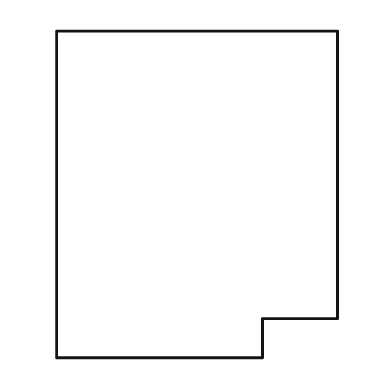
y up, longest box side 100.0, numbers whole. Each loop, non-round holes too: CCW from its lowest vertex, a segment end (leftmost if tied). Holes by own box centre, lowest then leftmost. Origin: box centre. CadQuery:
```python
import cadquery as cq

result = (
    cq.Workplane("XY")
    .moveTo(-43.0, -50.0)
    .lineTo(20.0, -50.0)
    .lineTo(20.0, -38.0)
    .lineTo(43.0, -38.0)
    .lineTo(43.0, 50.0)
    .lineTo(-43.0, 50.0)
    .close()
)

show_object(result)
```